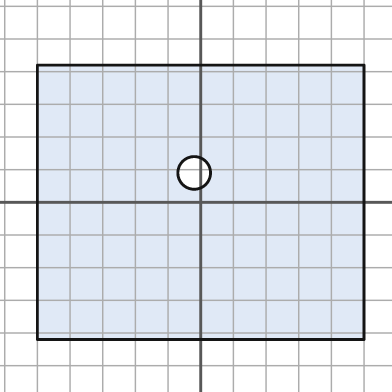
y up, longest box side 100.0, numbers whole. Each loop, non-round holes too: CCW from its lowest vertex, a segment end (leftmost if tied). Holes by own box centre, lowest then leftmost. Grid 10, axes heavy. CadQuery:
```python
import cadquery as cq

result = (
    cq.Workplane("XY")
    .moveTo(-50.0, -42.0)
    .lineTo(50.0, -42.0)
    .lineTo(50.0, 42.0)
    .lineTo(-50.0, 42.0)
    .close()
    .moveTo(-2.0, 9.0)
    .circle(5.0)
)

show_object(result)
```